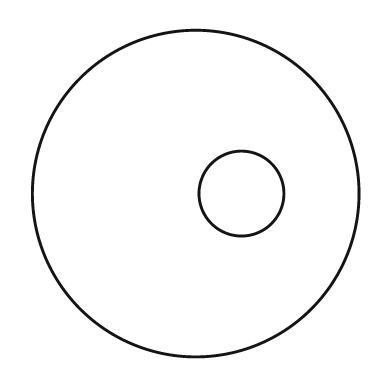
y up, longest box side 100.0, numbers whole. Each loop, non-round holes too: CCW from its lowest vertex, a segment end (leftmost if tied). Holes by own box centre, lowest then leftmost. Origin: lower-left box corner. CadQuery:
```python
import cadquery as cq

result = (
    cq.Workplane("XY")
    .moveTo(50.0, 50.0)
    .circle(50.0)
    .moveTo(64.0, 50.0)
    .circle(13.0)
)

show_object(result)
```